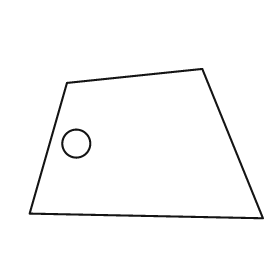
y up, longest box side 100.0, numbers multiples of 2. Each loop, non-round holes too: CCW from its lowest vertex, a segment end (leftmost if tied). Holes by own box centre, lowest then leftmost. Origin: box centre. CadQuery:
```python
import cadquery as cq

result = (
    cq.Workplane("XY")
    .moveTo(50.0, -32.0)
    .lineTo(24.0, 32.0)
    .lineTo(-34.0, 26.0)
    .lineTo(-50.0, -30.0)
    .close()
    .moveTo(-30.0, 0.0)
    .circle(6.0)
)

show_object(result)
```